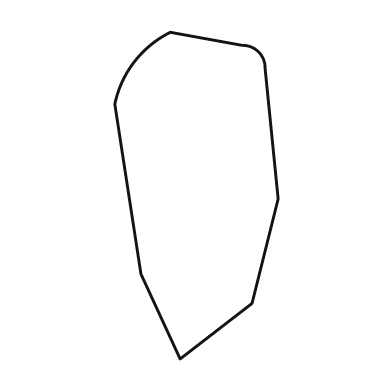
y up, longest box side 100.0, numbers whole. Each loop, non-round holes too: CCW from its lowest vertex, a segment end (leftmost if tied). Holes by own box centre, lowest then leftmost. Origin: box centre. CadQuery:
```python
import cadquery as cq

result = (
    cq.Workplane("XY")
    .moveTo(-5.0, -50.0)
    .lineTo(17.0, -33.0)
    .lineTo(25.0, -1.0)
    .lineTo(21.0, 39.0)
    .threePointArc((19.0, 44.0), (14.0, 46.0))
    .lineTo(-8.0, 50.0)
    .threePointArc((-19.0, 41.0), (-25.0, 28.0))
    .lineTo(-17.0, -24.0)
    .close()
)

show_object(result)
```